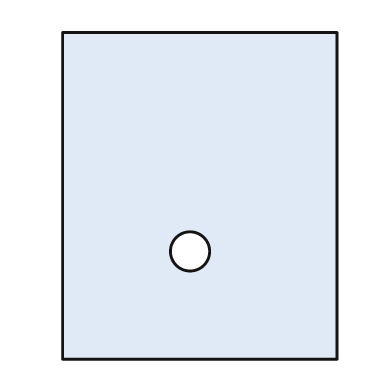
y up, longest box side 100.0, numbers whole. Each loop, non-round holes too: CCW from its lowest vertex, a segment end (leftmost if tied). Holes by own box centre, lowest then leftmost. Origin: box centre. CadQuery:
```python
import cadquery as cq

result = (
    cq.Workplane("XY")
    .moveTo(-42.0, -50.0)
    .lineTo(42.0, -50.0)
    .lineTo(42.0, 50.0)
    .lineTo(-42.0, 50.0)
    .close()
    .moveTo(-3.0, -17.0)
    .circle(6.0)
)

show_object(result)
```